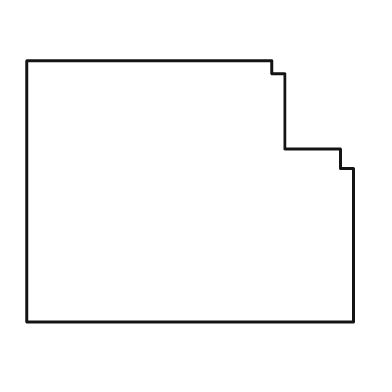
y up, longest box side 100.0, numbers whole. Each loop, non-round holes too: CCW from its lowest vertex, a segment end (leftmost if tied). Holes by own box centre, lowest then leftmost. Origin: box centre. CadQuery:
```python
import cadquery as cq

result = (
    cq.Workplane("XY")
    .moveTo(-50.0, -40.0)
    .lineTo(50.0, -40.0)
    .lineTo(50.0, 7.0)
    .lineTo(46.0, 7.0)
    .lineTo(46.0, 13.0)
    .lineTo(29.0, 13.0)
    .lineTo(29.0, 36.0)
    .lineTo(25.0, 36.0)
    .lineTo(25.0, 40.0)
    .lineTo(-50.0, 40.0)
    .close()
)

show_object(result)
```